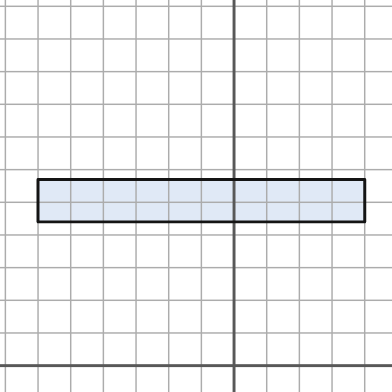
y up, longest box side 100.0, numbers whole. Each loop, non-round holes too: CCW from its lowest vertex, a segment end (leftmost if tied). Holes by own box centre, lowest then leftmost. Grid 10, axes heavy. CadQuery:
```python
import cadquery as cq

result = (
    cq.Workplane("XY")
    .moveTo(-60.0, 44.0)
    .lineTo(40.0, 44.0)
    .lineTo(40.0, 57.0)
    .lineTo(-60.0, 57.0)
    .close()
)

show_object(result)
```